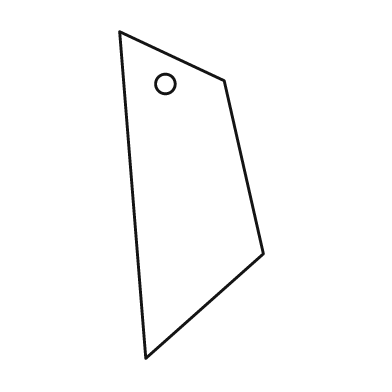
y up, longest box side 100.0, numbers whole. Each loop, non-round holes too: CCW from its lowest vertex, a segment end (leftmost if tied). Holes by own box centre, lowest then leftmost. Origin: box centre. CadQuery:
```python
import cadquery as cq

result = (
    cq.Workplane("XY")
    .moveTo(-14.0, -50.0)
    .lineTo(22.0, -18.0)
    .lineTo(10.0, 35.0)
    .lineTo(-22.0, 50.0)
    .close()
    .moveTo(-8.0, 34.0)
    .circle(3.0)
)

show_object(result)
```